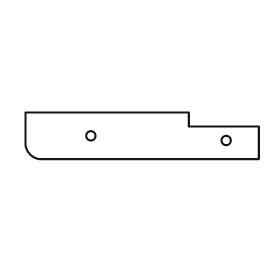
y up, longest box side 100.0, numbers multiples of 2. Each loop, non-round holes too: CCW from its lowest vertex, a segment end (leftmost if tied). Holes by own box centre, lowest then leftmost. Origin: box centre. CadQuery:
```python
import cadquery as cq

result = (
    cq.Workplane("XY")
    .moveTo(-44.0, -10.0)
    .lineTo(50.0, -10.0)
    .lineTo(50.0, 4.0)
    .lineTo(20.0, 4.0)
    .lineTo(20.0, 10.0)
    .lineTo(-50.0, 10.0)
    .lineTo(-50.0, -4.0)
    .threePointArc((-48.0, -8.0), (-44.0, -10.0))
    .close()
    .moveTo(36.0, -2.0)
    .circle(2.0)
    .moveTo(-22.0, 0.0)
    .circle(2.0)
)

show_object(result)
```